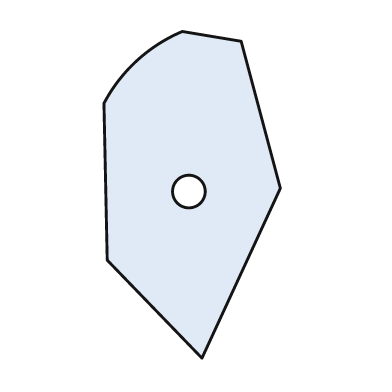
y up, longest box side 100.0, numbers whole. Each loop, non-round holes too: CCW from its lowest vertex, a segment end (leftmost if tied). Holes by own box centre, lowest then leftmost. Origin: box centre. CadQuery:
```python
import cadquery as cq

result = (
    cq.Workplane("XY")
    .moveTo(3.0, -50.0)
    .lineTo(27.0, 2.0)
    .lineTo(15.0, 47.0)
    .lineTo(-3.0, 50.0)
    .threePointArc((-17.0, 41.0), (-27.0, 28.0))
    .lineTo(-26.0, -20.0)
    .close()
    .moveTo(-1.0, 1.0)
    .circle(5.0)
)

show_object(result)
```